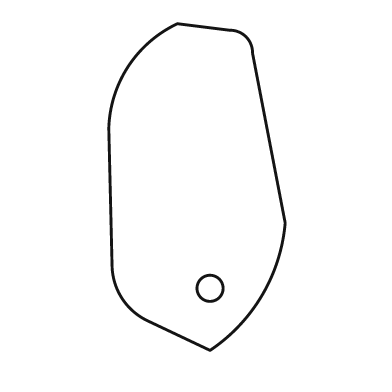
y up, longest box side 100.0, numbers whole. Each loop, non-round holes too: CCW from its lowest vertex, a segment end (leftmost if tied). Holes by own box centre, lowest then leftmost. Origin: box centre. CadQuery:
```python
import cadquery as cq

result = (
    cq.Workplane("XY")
    .moveTo(4.0, -50.0)
    .threePointArc((20.0, -33.0), (27.0, -11.0))
    .lineTo(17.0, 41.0)
    .threePointArc((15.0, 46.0), (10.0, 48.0))
    .lineTo(-6.0, 50.0)
    .threePointArc((-21.0, 37.0), (-27.0, 18.0))
    .lineTo(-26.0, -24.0)
    .threePointArc((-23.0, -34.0), (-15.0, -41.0))
    .close()
    .moveTo(4.0, -31.0)
    .circle(4.0)
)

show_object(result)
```